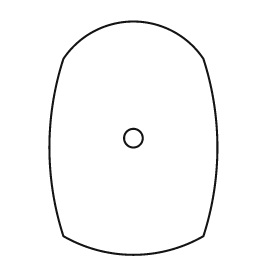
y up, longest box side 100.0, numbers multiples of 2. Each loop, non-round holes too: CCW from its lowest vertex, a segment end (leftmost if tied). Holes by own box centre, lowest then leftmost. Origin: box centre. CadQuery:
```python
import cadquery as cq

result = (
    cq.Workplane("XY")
    .moveTo(-30.0, -42.0)
    .threePointArc((0.0, -50.0), (30.0, -42.0))
    .threePointArc((36.0, -4.0), (30.0, 34.0))
    .threePointArc((0.0, 50.0), (-30.0, 34.0))
    .threePointArc((-36.0, -4.0), (-30.0, -42.0))
    .close()
    .moveTo(0.0, 0.0)
    .circle(4.0)
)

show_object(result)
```